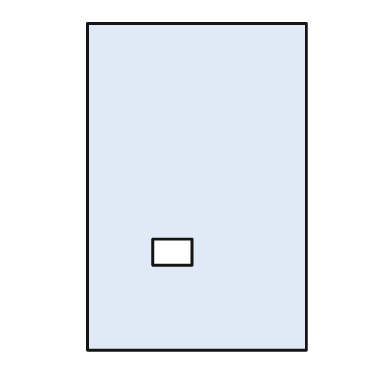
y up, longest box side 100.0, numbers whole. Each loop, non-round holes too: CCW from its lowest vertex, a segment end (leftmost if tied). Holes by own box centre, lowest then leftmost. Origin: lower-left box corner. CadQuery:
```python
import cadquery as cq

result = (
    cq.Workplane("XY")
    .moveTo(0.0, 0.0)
    .lineTo(67.0, 0.0)
    .lineTo(67.0, 100.0)
    .lineTo(0.0, 100.0)
    .close()
    .moveTo(20.0, 26.0)
    .lineTo(32.0, 26.0)
    .lineTo(32.0, 34.0)
    .lineTo(20.0, 34.0)
    .close()
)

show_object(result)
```